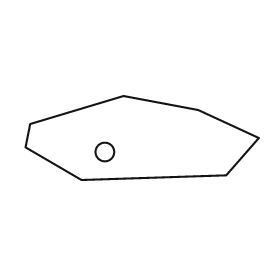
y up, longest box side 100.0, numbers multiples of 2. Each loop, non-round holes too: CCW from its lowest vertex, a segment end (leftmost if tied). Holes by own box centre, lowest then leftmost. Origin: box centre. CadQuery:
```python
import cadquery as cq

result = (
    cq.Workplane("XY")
    .moveTo(-26.0, -18.0)
    .lineTo(36.0, -16.0)
    .lineTo(50.0, 0.0)
    .lineTo(24.0, 12.0)
    .lineTo(-8.0, 18.0)
    .lineTo(-48.0, 6.0)
    .lineTo(-50.0, -4.0)
    .close()
    .moveTo(-16.0, -6.0)
    .circle(4.0)
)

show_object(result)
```